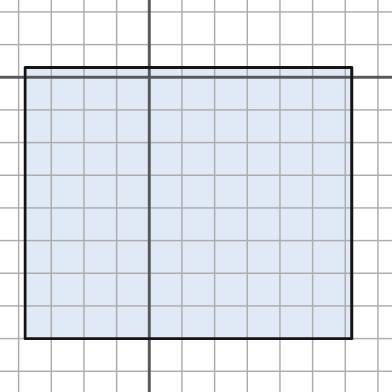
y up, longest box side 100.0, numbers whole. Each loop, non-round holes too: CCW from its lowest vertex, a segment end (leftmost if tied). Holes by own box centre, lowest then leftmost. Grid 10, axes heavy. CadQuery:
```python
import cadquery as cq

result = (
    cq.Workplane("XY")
    .moveTo(-38.0, -80.0)
    .lineTo(62.0, -80.0)
    .lineTo(62.0, 3.0)
    .lineTo(-38.0, 3.0)
    .close()
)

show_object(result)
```